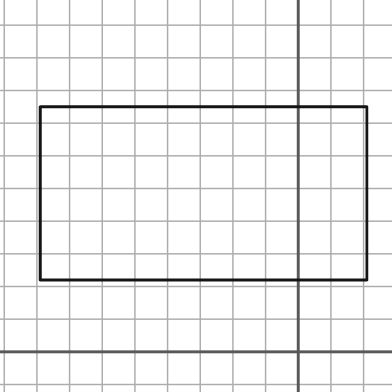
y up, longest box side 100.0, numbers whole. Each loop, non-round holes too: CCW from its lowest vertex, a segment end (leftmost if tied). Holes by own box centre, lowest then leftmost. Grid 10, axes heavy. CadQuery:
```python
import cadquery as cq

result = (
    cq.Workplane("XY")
    .moveTo(-79.0, 22.0)
    .lineTo(21.0, 22.0)
    .lineTo(21.0, 75.0)
    .lineTo(-79.0, 75.0)
    .close()
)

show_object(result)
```